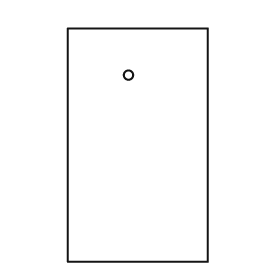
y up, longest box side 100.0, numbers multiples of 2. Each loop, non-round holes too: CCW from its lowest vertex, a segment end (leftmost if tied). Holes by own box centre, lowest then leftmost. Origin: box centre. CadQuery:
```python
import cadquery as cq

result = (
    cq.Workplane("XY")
    .moveTo(-30.0, -50.0)
    .lineTo(30.0, -50.0)
    .lineTo(30.0, 50.0)
    .lineTo(-30.0, 50.0)
    .close()
    .moveTo(-4.0, 30.0)
    .circle(2.0)
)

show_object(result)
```